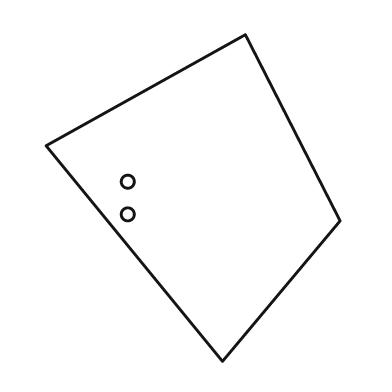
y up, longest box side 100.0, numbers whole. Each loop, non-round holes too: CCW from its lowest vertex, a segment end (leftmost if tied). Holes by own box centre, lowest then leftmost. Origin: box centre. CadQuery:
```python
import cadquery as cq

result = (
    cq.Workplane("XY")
    .moveTo(9.0, -50.0)
    .lineTo(45.0, -7.0)
    .lineTo(16.0, 50.0)
    .lineTo(-45.0, 16.0)
    .close()
    .moveTo(-20.0, -5.0)
    .circle(2.0)
    .moveTo(-20.0, 5.0)
    .circle(2.0)
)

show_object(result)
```